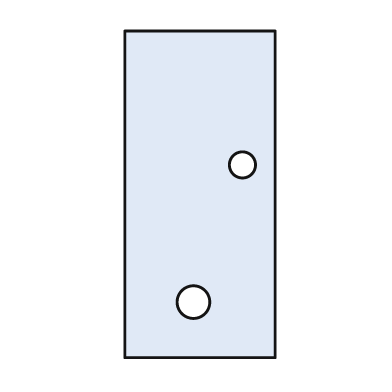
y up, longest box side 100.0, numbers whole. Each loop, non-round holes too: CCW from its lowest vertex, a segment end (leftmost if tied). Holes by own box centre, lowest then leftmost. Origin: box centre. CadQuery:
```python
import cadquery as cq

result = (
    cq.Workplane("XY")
    .moveTo(-23.0, -50.0)
    .lineTo(23.0, -50.0)
    .lineTo(23.0, 50.0)
    .lineTo(-23.0, 50.0)
    .close()
    .moveTo(-2.0, -33.0)
    .circle(5.0)
    .moveTo(13.0, 9.0)
    .circle(4.0)
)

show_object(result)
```